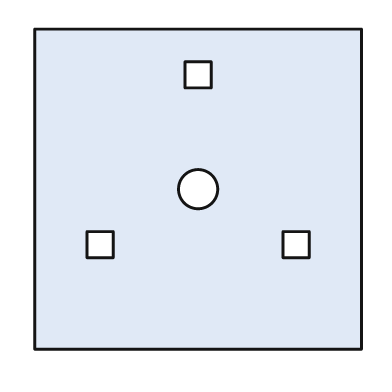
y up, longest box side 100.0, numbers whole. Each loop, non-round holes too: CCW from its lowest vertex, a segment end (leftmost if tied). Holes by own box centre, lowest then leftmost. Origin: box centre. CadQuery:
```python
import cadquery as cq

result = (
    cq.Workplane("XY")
    .moveTo(-50.0, -49.0)
    .lineTo(50.0, -49.0)
    .lineTo(50.0, 49.0)
    .lineTo(-50.0, 49.0)
    .close()
    .moveTo(-34.0, -21.0)
    .lineTo(-26.0, -21.0)
    .lineTo(-26.0, -13.0)
    .lineTo(-34.0, -13.0)
    .close()
    .moveTo(26.0, -21.0)
    .lineTo(34.0, -21.0)
    .lineTo(34.0, -13.0)
    .lineTo(26.0, -13.0)
    .close()
    .moveTo(0.0, 0.0)
    .circle(6.0)
    .moveTo(-4.0, 31.0)
    .lineTo(4.0, 31.0)
    .lineTo(4.0, 39.0)
    .lineTo(-4.0, 39.0)
    .close()
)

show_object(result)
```